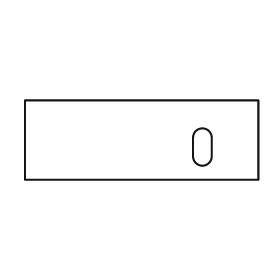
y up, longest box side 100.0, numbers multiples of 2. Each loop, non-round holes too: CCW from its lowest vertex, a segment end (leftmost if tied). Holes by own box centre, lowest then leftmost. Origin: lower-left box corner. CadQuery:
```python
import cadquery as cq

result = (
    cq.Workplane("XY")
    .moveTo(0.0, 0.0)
    .lineTo(100.0, 0.0)
    .lineTo(100.0, 34.0)
    .lineTo(0.0, 34.0)
    .close()
    .moveTo(72.0, 10.0)
    .threePointArc((76.0, 6.0), (80.0, 10.0))
    .lineTo(80.0, 18.0)
    .threePointArc((76.0, 22.0), (72.0, 18.0))
    .close()
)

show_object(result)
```